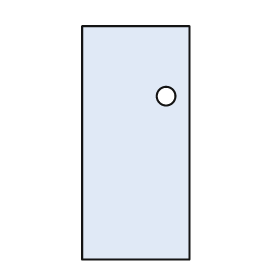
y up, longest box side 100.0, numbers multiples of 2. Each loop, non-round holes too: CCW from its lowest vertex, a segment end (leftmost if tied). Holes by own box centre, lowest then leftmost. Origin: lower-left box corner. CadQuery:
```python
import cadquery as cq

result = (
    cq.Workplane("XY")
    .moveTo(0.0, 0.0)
    .lineTo(46.0, 0.0)
    .lineTo(46.0, 100.0)
    .lineTo(0.0, 100.0)
    .close()
    .moveTo(36.0, 70.0)
    .circle(4.0)
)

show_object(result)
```